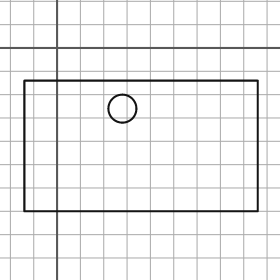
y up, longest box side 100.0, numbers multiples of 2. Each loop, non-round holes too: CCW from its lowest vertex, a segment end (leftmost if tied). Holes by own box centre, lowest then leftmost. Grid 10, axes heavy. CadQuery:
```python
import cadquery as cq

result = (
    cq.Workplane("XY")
    .moveTo(-14.0, -70.0)
    .lineTo(86.0, -70.0)
    .lineTo(86.0, -14.0)
    .lineTo(-14.0, -14.0)
    .close()
    .moveTo(28.0, -26.0)
    .circle(6.0)
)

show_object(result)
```